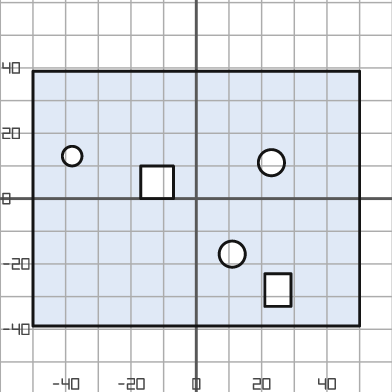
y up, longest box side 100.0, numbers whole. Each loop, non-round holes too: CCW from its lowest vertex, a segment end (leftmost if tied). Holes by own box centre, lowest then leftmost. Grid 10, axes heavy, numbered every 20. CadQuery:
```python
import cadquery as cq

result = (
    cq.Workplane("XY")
    .moveTo(-50.0, -39.0)
    .lineTo(50.0, -39.0)
    .lineTo(50.0, 39.0)
    .lineTo(-50.0, 39.0)
    .close()
    .moveTo(21.0, -33.0)
    .lineTo(29.0, -33.0)
    .lineTo(29.0, -23.0)
    .lineTo(21.0, -23.0)
    .close()
    .moveTo(11.0, -17.0)
    .circle(4.0)
    .moveTo(-17.0, 0.0)
    .lineTo(-7.0, 0.0)
    .lineTo(-7.0, 10.0)
    .lineTo(-17.0, 10.0)
    .close()
    .moveTo(23.0, 11.0)
    .circle(4.0)
    .moveTo(-38.0, 13.0)
    .circle(3.0)
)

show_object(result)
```